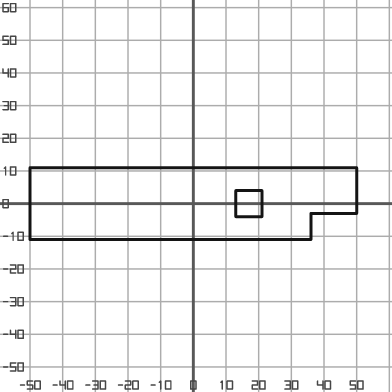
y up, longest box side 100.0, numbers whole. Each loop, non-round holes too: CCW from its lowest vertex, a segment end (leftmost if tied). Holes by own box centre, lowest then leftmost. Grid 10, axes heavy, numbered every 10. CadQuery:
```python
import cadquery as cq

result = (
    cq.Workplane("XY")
    .moveTo(-50.0, -11.0)
    .lineTo(36.0, -11.0)
    .lineTo(36.0, -3.0)
    .lineTo(50.0, -3.0)
    .lineTo(50.0, 11.0)
    .lineTo(-50.0, 11.0)
    .close()
    .moveTo(13.0, -4.0)
    .lineTo(21.0, -4.0)
    .lineTo(21.0, 4.0)
    .lineTo(13.0, 4.0)
    .close()
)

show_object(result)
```